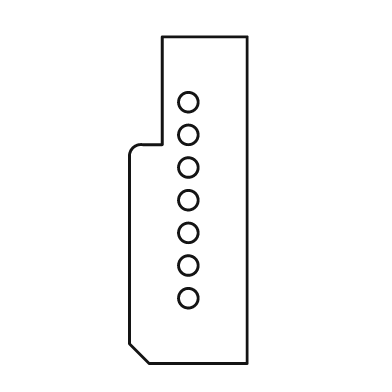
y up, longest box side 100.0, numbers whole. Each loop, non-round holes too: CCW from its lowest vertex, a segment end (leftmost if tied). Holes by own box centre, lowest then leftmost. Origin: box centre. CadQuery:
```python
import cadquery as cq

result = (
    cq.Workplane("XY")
    .moveTo(-12.0, -50.0)
    .lineTo(18.0, -50.0)
    .lineTo(18.0, 50.0)
    .lineTo(-8.0, 50.0)
    .lineTo(-8.0, 17.0)
    .lineTo(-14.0, 17.0)
    .threePointArc((-17.0, 16.0), (-18.0, 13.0))
    .lineTo(-18.0, -44.0)
    .close()
    .moveTo(0.0, -30.0)
    .circle(3.0)
    .moveTo(0.0, -20.0)
    .circle(3.0)
    .moveTo(0.0, -10.0)
    .circle(3.0)
    .moveTo(0.0, 0.0)
    .circle(3.0)
    .moveTo(0.0, 10.0)
    .circle(3.0)
    .moveTo(0.0, 20.0)
    .circle(3.0)
    .moveTo(0.0, 30.0)
    .circle(3.0)
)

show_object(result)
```